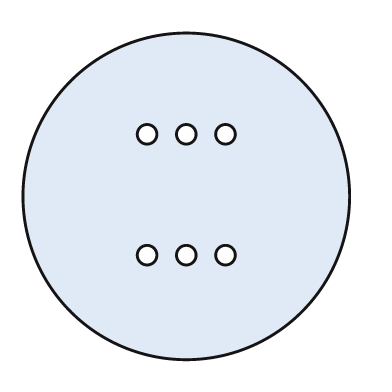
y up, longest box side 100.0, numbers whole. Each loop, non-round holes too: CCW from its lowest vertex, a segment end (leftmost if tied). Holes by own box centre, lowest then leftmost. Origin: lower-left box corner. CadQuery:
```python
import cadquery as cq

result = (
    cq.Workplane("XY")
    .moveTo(50.0, 50.0)
    .circle(50.0)
    .moveTo(38.0, 32.0)
    .circle(3.0)
    .moveTo(50.0, 32.0)
    .circle(3.0)
    .moveTo(62.0, 32.0)
    .circle(3.0)
    .moveTo(38.0, 69.0)
    .circle(3.0)
    .moveTo(50.0, 69.0)
    .circle(3.0)
    .moveTo(62.0, 69.0)
    .circle(3.0)
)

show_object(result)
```